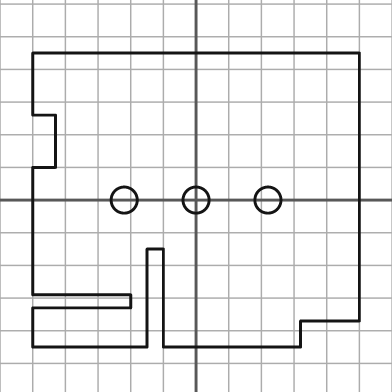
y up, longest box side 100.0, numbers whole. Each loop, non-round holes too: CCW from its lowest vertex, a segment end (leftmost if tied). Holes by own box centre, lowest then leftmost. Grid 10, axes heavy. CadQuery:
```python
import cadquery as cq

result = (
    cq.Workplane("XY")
    .moveTo(-50.0, -45.0)
    .lineTo(-15.0, -45.0)
    .lineTo(-15.0, -15.0)
    .lineTo(-10.0, -15.0)
    .lineTo(-10.0, -45.0)
    .lineTo(32.0, -45.0)
    .lineTo(32.0, -37.0)
    .lineTo(50.0, -37.0)
    .lineTo(50.0, 45.0)
    .lineTo(-50.0, 45.0)
    .lineTo(-50.0, 26.0)
    .lineTo(-43.0, 26.0)
    .lineTo(-43.0, 10.0)
    .lineTo(-50.0, 10.0)
    .lineTo(-50.0, -29.0)
    .lineTo(-20.0, -29.0)
    .lineTo(-20.0, -33.0)
    .lineTo(-50.0, -33.0)
    .close()
    .moveTo(-22.0, 0.0)
    .circle(4.0)
    .moveTo(0.0, 0.0)
    .circle(4.0)
    .moveTo(22.0, 0.0)
    .circle(4.0)
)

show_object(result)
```